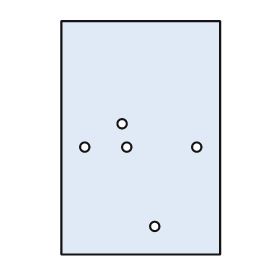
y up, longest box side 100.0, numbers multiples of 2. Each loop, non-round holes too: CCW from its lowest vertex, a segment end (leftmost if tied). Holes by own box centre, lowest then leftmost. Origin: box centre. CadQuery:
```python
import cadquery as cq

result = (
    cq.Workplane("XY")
    .moveTo(-34.0, -50.0)
    .lineTo(34.0, -50.0)
    .lineTo(34.0, 50.0)
    .lineTo(-34.0, 50.0)
    .close()
    .moveTo(6.0, -38.0)
    .circle(2.0)
    .moveTo(-24.0, -4.0)
    .circle(2.0)
    .moveTo(-6.0, -4.0)
    .circle(2.0)
    .moveTo(24.0, -4.0)
    .circle(2.0)
    .moveTo(-8.0, 6.0)
    .circle(2.0)
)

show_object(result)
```